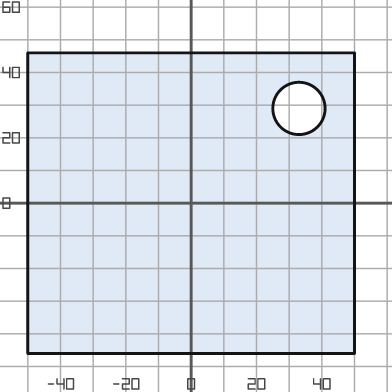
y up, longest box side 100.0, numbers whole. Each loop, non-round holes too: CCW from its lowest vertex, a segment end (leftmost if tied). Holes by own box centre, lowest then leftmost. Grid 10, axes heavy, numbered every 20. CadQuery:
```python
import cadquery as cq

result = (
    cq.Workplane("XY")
    .moveTo(-50.0, -46.0)
    .lineTo(50.0, -46.0)
    .lineTo(50.0, 46.0)
    .lineTo(-50.0, 46.0)
    .close()
    .moveTo(33.0, 29.0)
    .circle(8.0)
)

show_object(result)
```